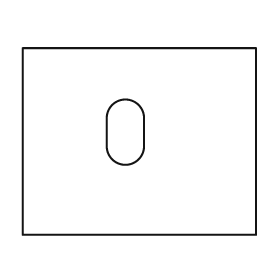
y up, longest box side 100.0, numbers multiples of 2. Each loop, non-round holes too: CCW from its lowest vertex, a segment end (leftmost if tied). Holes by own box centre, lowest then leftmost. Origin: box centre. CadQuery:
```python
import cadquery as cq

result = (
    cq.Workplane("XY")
    .moveTo(-50.0, -40.0)
    .lineTo(50.0, -40.0)
    .lineTo(50.0, 40.0)
    .lineTo(-50.0, 40.0)
    .close()
    .moveTo(-14.0, -2.0)
    .threePointArc((-6.0, -10.0), (2.0, -2.0))
    .lineTo(2.0, 10.0)
    .threePointArc((-6.0, 18.0), (-14.0, 10.0))
    .close()
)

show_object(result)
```